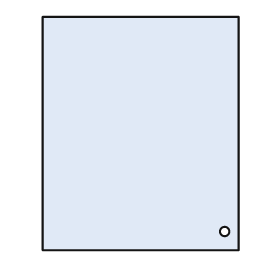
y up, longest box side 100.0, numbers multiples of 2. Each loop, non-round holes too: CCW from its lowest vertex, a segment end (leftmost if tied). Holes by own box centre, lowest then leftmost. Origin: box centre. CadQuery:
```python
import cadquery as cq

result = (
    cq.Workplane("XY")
    .moveTo(-42.0, -50.0)
    .lineTo(42.0, -50.0)
    .lineTo(42.0, 50.0)
    .lineTo(-42.0, 50.0)
    .close()
    .moveTo(36.0, -42.0)
    .circle(2.0)
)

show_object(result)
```